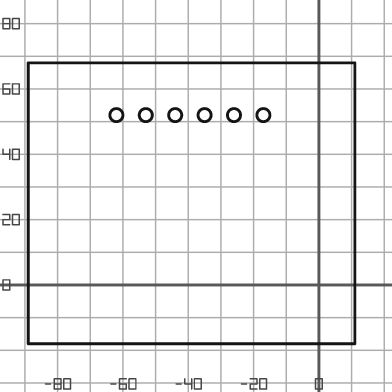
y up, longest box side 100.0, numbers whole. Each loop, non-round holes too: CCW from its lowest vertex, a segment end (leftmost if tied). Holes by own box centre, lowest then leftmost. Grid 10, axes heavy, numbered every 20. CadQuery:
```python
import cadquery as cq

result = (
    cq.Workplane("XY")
    .moveTo(-89.0, -18.0)
    .lineTo(11.0, -18.0)
    .lineTo(11.0, 68.0)
    .lineTo(-89.0, 68.0)
    .close()
    .moveTo(-62.0, 52.0)
    .circle(2.0)
    .moveTo(-53.0, 52.0)
    .circle(2.0)
    .moveTo(-44.0, 52.0)
    .circle(2.0)
    .moveTo(-35.0, 52.0)
    .circle(2.0)
    .moveTo(-26.0, 52.0)
    .circle(2.0)
    .moveTo(-17.0, 52.0)
    .circle(2.0)
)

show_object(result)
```